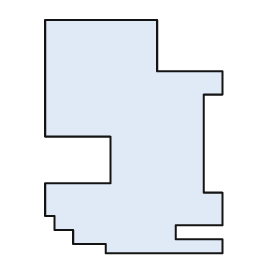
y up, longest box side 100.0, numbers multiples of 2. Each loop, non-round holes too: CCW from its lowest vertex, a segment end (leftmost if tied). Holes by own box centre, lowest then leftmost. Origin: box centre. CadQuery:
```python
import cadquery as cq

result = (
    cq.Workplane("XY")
    .moveTo(-12.0, -50.0)
    .lineTo(38.0, -50.0)
    .lineTo(38.0, -44.0)
    .lineTo(18.0, -44.0)
    .lineTo(18.0, -38.0)
    .lineTo(38.0, -38.0)
    .lineTo(38.0, -24.0)
    .lineTo(30.0, -24.0)
    .lineTo(30.0, 18.0)
    .lineTo(38.0, 18.0)
    .lineTo(38.0, 28.0)
    .lineTo(10.0, 28.0)
    .lineTo(10.0, 50.0)
    .lineTo(-38.0, 50.0)
    .lineTo(-38.0, 0.0)
    .lineTo(-10.0, 0.0)
    .lineTo(-10.0, -20.0)
    .lineTo(-38.0, -20.0)
    .lineTo(-38.0, -34.0)
    .lineTo(-34.0, -34.0)
    .lineTo(-34.0, -40.0)
    .lineTo(-26.0, -40.0)
    .lineTo(-26.0, -46.0)
    .lineTo(-12.0, -46.0)
    .close()
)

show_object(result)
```